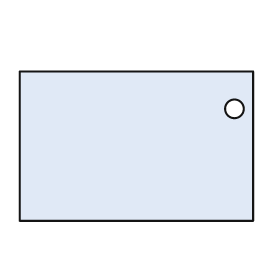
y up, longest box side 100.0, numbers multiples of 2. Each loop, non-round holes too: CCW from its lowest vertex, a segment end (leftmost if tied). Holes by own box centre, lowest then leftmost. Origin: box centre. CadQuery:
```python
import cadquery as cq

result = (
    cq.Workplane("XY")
    .moveTo(-50.0, -32.0)
    .lineTo(50.0, -32.0)
    .lineTo(50.0, 32.0)
    .lineTo(-50.0, 32.0)
    .close()
    .moveTo(42.0, 16.0)
    .circle(4.0)
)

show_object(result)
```